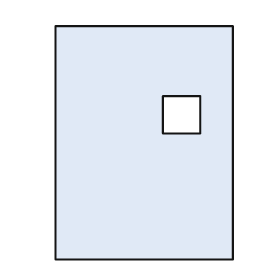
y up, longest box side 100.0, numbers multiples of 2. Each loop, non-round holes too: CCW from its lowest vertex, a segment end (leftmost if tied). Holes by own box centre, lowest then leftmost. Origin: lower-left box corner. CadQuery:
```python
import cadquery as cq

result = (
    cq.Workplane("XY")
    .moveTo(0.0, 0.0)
    .lineTo(76.0, 0.0)
    .lineTo(76.0, 100.0)
    .lineTo(0.0, 100.0)
    .close()
    .moveTo(46.0, 54.0)
    .lineTo(62.0, 54.0)
    .lineTo(62.0, 70.0)
    .lineTo(46.0, 70.0)
    .close()
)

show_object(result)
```